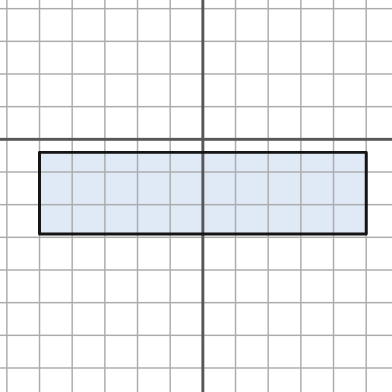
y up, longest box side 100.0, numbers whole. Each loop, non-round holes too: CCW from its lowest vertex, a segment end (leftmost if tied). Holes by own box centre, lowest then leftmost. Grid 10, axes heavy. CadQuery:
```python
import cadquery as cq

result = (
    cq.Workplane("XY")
    .moveTo(-50.0, -29.0)
    .lineTo(50.0, -29.0)
    .lineTo(50.0, -4.0)
    .lineTo(-50.0, -4.0)
    .close()
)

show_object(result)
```